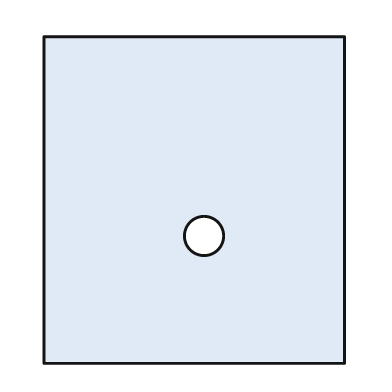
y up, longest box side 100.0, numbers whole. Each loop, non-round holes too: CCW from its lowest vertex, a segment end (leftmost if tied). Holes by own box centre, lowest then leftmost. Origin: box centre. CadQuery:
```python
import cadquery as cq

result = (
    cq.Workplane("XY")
    .moveTo(-46.0, -50.0)
    .lineTo(46.0, -50.0)
    .lineTo(46.0, 50.0)
    .lineTo(-46.0, 50.0)
    .close()
    .moveTo(3.0, -11.0)
    .circle(6.0)
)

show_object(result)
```